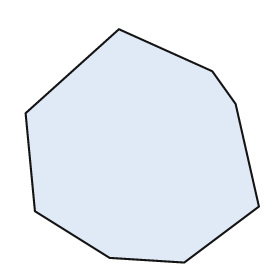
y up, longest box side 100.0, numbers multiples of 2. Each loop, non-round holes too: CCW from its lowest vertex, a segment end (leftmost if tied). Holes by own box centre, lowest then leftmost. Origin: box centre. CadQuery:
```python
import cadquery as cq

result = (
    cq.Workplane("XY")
    .moveTo(18.0, -50.0)
    .lineTo(50.0, -26.0)
    .lineTo(40.0, 18.0)
    .lineTo(30.0, 32.0)
    .lineTo(-10.0, 50.0)
    .lineTo(-50.0, 14.0)
    .lineTo(-46.0, -28.0)
    .lineTo(-14.0, -48.0)
    .close()
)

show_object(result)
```